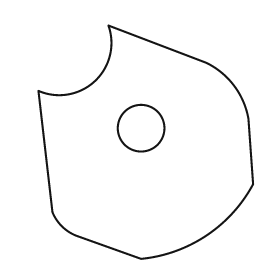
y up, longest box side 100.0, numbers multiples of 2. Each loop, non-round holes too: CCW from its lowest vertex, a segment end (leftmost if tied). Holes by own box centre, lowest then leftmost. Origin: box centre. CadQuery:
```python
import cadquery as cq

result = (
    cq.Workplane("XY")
    .moveTo(-2.0, -50.0)
    .threePointArc((26.0, -40.0), (46.0, -18.0))
    .lineTo(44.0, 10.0)
    .threePointArc((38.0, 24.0), (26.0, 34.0))
    .lineTo(-16.0, 50.0)
    .threePointArc((-22.0, 26.0), (-46.0, 22.0))
    .lineTo(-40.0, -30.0)
    .threePointArc((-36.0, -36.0), (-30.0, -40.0))
    .close()
    .moveTo(-2.0, 6.0)
    .circle(10.0)
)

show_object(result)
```